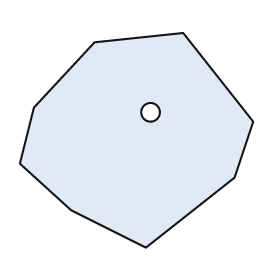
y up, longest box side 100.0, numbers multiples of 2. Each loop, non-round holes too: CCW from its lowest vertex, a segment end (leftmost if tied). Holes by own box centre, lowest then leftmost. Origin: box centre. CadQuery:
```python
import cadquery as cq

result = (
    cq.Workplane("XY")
    .moveTo(4.0, -46.0)
    .lineTo(42.0, -16.0)
    .lineTo(50.0, 8.0)
    .lineTo(20.0, 46.0)
    .lineTo(-18.0, 42.0)
    .lineTo(-44.0, 14.0)
    .lineTo(-50.0, -10.0)
    .lineTo(-28.0, -30.0)
    .close()
    .moveTo(6.0, 12.0)
    .circle(4.0)
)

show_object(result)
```